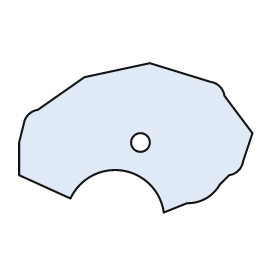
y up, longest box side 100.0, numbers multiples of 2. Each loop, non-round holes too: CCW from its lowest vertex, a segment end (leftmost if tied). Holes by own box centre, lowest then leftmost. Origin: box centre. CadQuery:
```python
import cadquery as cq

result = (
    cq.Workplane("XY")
    .moveTo(12.0, -32.0)
    .lineTo(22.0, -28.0)
    .threePointArc((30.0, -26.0), (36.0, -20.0))
    .lineTo(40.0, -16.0)
    .threePointArc((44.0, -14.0), (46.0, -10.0))
    .lineTo(50.0, 2.0)
    .lineTo(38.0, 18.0)
    .threePointArc((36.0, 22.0), (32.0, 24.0))
    .lineTo(6.0, 32.0)
    .lineTo(-22.0, 26.0)
    .lineTo(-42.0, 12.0)
    .threePointArc((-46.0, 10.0), (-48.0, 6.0))
    .lineTo(-50.0, -2.0)
    .lineTo(-50.0, -16.0)
    .lineTo(-28.0, -26.0)
    .threePointArc((-6.0, -14.0), (12.0, -32.0))
    .close()
    .moveTo(2.0, -2.0)
    .circle(4.0)
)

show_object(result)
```